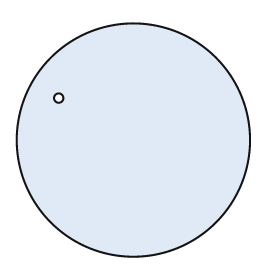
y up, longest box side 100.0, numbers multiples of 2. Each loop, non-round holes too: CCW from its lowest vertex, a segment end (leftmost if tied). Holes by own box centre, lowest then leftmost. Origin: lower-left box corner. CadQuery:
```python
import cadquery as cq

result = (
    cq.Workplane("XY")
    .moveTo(50.0, 50.0)
    .circle(50.0)
    .moveTo(18.0, 68.0)
    .circle(2.0)
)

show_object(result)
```